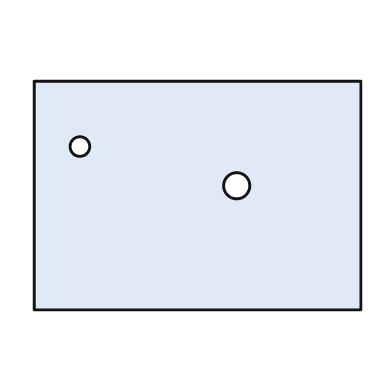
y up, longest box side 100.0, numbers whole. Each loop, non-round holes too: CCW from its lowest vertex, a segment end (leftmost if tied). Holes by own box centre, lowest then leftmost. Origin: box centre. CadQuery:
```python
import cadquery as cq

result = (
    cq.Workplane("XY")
    .moveTo(-50.0, -35.0)
    .lineTo(50.0, -35.0)
    .lineTo(50.0, 35.0)
    .lineTo(-50.0, 35.0)
    .close()
    .moveTo(12.0, 3.0)
    .circle(4.0)
    .moveTo(-36.0, 15.0)
    .circle(3.0)
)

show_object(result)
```